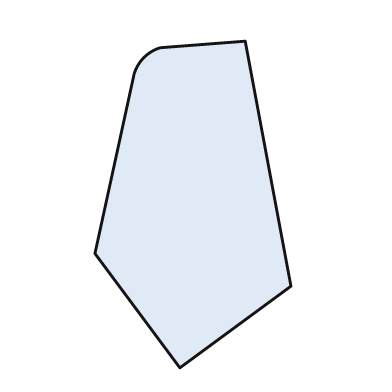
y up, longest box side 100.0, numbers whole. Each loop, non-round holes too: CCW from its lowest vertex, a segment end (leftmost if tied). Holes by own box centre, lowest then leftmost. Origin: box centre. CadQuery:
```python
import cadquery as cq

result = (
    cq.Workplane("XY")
    .moveTo(-4.0, -50.0)
    .lineTo(30.0, -25.0)
    .lineTo(16.0, 50.0)
    .lineTo(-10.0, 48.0)
    .threePointArc((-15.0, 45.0), (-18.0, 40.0))
    .lineTo(-30.0, -15.0)
    .close()
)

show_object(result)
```